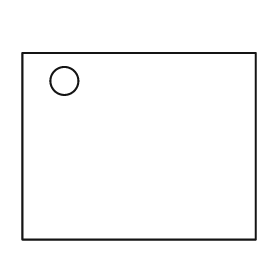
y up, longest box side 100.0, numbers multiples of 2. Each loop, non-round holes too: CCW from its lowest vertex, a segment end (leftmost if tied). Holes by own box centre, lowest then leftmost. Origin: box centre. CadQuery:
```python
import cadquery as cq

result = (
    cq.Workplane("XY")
    .moveTo(-50.0, -40.0)
    .lineTo(50.0, -40.0)
    .lineTo(50.0, 40.0)
    .lineTo(-50.0, 40.0)
    .close()
    .moveTo(-32.0, 28.0)
    .circle(6.0)
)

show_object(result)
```